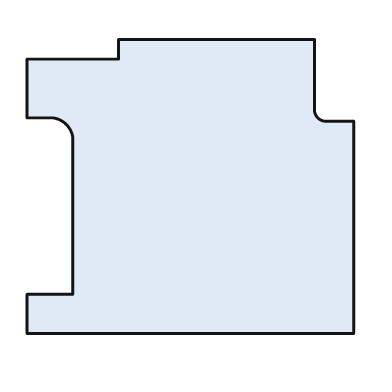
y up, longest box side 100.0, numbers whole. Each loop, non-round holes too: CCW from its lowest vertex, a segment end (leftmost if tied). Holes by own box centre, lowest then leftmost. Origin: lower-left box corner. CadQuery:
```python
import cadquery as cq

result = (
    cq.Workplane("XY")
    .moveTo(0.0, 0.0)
    .lineTo(100.0, 0.0)
    .lineTo(100.0, 65.0)
    .lineTo(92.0, 65.0)
    .threePointArc((89.0, 66.0), (88.0, 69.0))
    .lineTo(88.0, 90.0)
    .lineTo(28.0, 90.0)
    .lineTo(28.0, 84.0)
    .lineTo(0.0, 84.0)
    .lineTo(0.0, 66.0)
    .lineTo(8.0, 66.0)
    .threePointArc((12.0, 64.0), (14.0, 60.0))
    .lineTo(14.0, 12.0)
    .lineTo(0.0, 12.0)
    .close()
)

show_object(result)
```